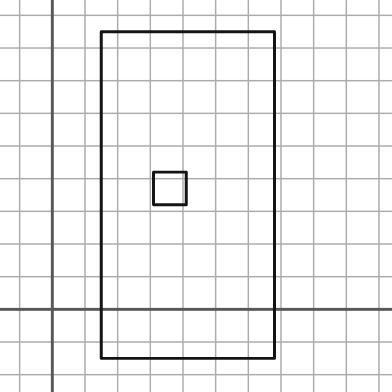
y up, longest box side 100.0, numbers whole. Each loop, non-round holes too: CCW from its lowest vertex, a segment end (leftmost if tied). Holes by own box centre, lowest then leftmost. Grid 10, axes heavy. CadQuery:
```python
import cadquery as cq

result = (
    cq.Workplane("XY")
    .moveTo(15.0, -15.0)
    .lineTo(68.0, -15.0)
    .lineTo(68.0, 85.0)
    .lineTo(15.0, 85.0)
    .close()
    .moveTo(31.0, 32.0)
    .lineTo(41.0, 32.0)
    .lineTo(41.0, 42.0)
    .lineTo(31.0, 42.0)
    .close()
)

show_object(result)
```